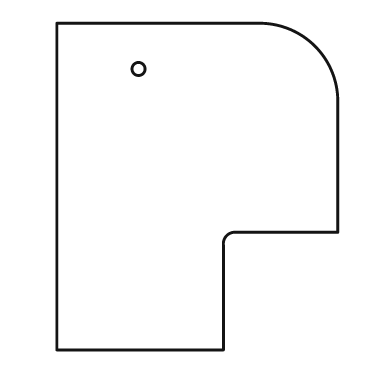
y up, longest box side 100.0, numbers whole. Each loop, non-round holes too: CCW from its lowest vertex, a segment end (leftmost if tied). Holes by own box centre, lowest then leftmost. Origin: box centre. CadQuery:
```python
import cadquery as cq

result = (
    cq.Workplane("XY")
    .moveTo(-43.0, -50.0)
    .lineTo(8.0, -50.0)
    .lineTo(8.0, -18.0)
    .threePointArc((9.0, -15.0), (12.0, -14.0))
    .lineTo(43.0, -14.0)
    .lineTo(43.0, 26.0)
    .threePointArc((36.0, 43.0), (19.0, 50.0))
    .lineTo(-43.0, 50.0)
    .close()
    .moveTo(-18.0, 36.0)
    .circle(2.0)
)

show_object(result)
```